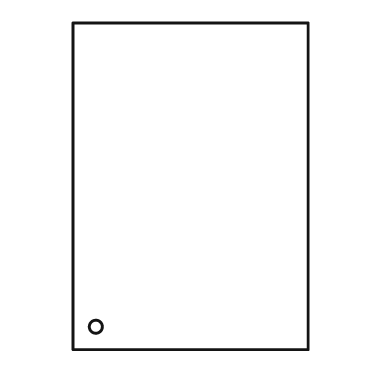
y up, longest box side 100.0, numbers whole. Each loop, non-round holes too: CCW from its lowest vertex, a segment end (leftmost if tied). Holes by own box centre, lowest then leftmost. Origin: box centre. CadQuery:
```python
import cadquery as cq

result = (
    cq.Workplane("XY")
    .moveTo(-36.0, -50.0)
    .lineTo(36.0, -50.0)
    .lineTo(36.0, 50.0)
    .lineTo(-36.0, 50.0)
    .close()
    .moveTo(-29.0, -43.0)
    .circle(2.0)
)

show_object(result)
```